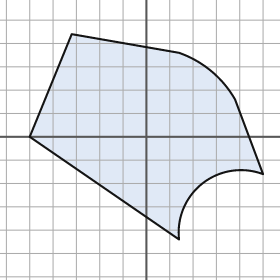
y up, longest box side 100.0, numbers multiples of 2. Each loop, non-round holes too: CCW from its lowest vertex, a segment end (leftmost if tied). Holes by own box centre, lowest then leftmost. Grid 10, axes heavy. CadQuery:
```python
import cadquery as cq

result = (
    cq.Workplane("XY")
    .moveTo(14.0, -44.0)
    .threePointArc((24.0, -20.0), (50.0, -16.0))
    .lineTo(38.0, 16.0)
    .threePointArc((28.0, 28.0), (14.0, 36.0))
    .lineTo(-32.0, 44.0)
    .lineTo(-50.0, 0.0)
    .close()
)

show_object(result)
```